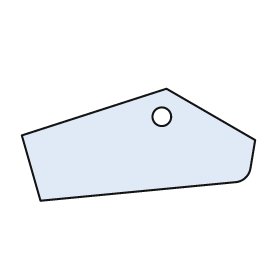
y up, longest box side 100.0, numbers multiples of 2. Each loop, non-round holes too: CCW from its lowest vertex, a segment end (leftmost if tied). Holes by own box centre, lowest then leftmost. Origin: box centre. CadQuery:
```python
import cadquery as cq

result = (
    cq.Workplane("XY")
    .moveTo(-42.0, -24.0)
    .lineTo(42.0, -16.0)
    .threePointArc((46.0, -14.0), (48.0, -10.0))
    .lineTo(50.0, 2.0)
    .lineTo(12.0, 24.0)
    .lineTo(-50.0, 4.0)
    .close()
    .moveTo(10.0, 12.0)
    .circle(4.0)
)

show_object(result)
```